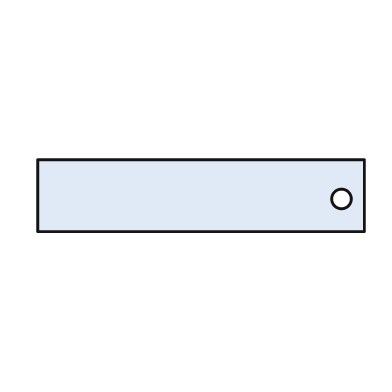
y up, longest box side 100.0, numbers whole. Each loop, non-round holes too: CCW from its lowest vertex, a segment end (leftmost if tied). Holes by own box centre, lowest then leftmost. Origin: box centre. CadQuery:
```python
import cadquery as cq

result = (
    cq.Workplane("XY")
    .moveTo(-50.0, -11.0)
    .lineTo(50.0, -11.0)
    .lineTo(50.0, 11.0)
    .lineTo(-50.0, 11.0)
    .close()
    .moveTo(43.0, -1.0)
    .circle(3.0)
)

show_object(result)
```